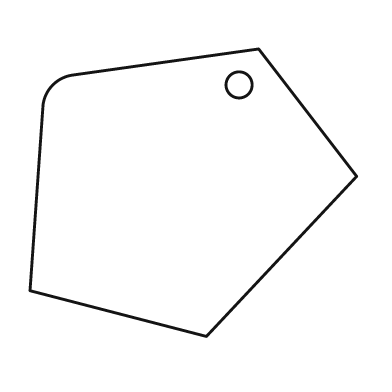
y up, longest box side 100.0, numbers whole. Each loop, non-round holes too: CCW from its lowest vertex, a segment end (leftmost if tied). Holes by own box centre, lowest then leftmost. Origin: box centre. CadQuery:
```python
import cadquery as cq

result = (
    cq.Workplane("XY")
    .moveTo(4.0, -44.0)
    .lineTo(50.0, 5.0)
    .lineTo(20.0, 44.0)
    .lineTo(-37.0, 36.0)
    .threePointArc((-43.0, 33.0), (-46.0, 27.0))
    .lineTo(-50.0, -30.0)
    .close()
    .moveTo(14.0, 33.0)
    .circle(4.0)
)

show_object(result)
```